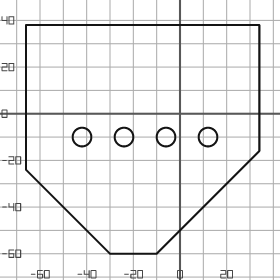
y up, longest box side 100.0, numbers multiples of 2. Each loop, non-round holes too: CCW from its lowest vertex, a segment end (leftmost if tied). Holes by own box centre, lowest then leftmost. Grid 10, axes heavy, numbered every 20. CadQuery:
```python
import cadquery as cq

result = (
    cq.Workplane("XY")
    .moveTo(-30.0, -60.0)
    .lineTo(-10.0, -60.0)
    .lineTo(34.0, -16.0)
    .lineTo(34.0, 38.0)
    .lineTo(-66.0, 38.0)
    .lineTo(-66.0, -24.0)
    .close()
    .moveTo(-42.0, -10.0)
    .circle(4.0)
    .moveTo(-24.0, -10.0)
    .circle(4.0)
    .moveTo(-6.0, -10.0)
    .circle(4.0)
    .moveTo(12.0, -10.0)
    .circle(4.0)
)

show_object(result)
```